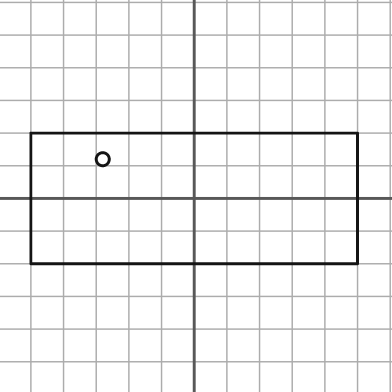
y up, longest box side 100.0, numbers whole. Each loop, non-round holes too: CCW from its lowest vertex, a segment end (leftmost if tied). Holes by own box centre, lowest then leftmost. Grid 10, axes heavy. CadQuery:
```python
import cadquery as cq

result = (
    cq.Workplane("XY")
    .moveTo(-50.0, -20.0)
    .lineTo(50.0, -20.0)
    .lineTo(50.0, 20.0)
    .lineTo(-50.0, 20.0)
    .close()
    .moveTo(-28.0, 12.0)
    .circle(2.0)
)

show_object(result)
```